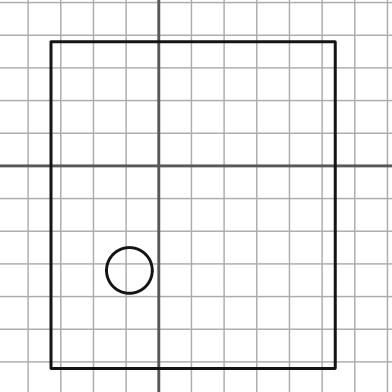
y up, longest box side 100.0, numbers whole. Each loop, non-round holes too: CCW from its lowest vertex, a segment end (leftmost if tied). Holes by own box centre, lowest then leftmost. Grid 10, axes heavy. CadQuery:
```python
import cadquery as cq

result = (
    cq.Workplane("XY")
    .moveTo(-33.0, -62.0)
    .lineTo(54.0, -62.0)
    .lineTo(54.0, 38.0)
    .lineTo(-33.0, 38.0)
    .close()
    .moveTo(-9.0, -32.0)
    .circle(7.0)
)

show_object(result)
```